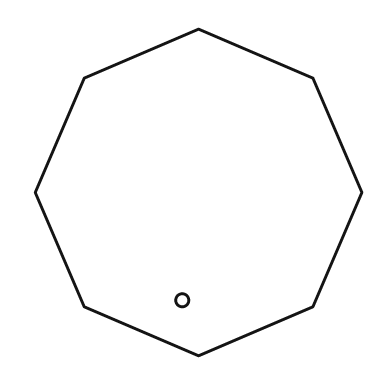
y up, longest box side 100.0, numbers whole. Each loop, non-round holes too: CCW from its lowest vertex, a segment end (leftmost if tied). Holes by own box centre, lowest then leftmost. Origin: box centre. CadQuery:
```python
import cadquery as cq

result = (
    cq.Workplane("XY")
    .moveTo(0.0, -50.0)
    .lineTo(35.0, -35.0)
    .lineTo(50.0, 0.0)
    .lineTo(35.0, 35.0)
    .lineTo(0.0, 50.0)
    .lineTo(-35.0, 35.0)
    .lineTo(-50.0, 0.0)
    .lineTo(-35.0, -35.0)
    .close()
    .moveTo(-5.0, -33.0)
    .circle(2.0)
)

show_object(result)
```